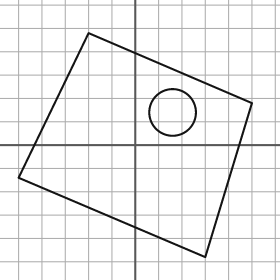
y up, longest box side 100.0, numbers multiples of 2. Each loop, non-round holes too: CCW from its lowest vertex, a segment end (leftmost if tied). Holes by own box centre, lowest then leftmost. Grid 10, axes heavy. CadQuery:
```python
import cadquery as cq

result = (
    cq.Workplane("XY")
    .moveTo(30.0, -48.0)
    .lineTo(50.0, 18.0)
    .lineTo(-20.0, 48.0)
    .lineTo(-50.0, -14.0)
    .close()
    .moveTo(16.0, 14.0)
    .circle(10.0)
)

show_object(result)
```